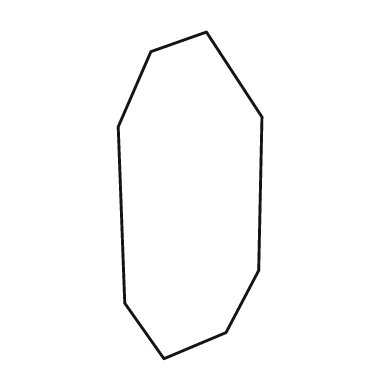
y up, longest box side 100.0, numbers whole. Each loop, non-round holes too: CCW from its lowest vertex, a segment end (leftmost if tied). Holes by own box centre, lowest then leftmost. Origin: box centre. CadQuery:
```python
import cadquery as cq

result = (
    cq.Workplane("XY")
    .moveTo(-8.0, -50.0)
    .lineTo(11.0, -42.0)
    .lineTo(21.0, -23.0)
    .lineTo(22.0, 24.0)
    .lineTo(5.0, 50.0)
    .lineTo(-12.0, 44.0)
    .lineTo(-22.0, 21.0)
    .lineTo(-20.0, -33.0)
    .close()
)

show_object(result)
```